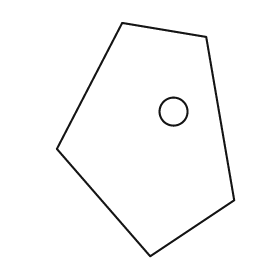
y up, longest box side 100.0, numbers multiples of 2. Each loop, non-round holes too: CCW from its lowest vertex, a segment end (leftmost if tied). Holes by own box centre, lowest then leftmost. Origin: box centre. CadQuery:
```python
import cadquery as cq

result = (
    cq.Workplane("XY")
    .moveTo(2.0, -50.0)
    .lineTo(38.0, -26.0)
    .lineTo(26.0, 44.0)
    .lineTo(-10.0, 50.0)
    .lineTo(-38.0, -4.0)
    .close()
    .moveTo(12.0, 12.0)
    .circle(6.0)
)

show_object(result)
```